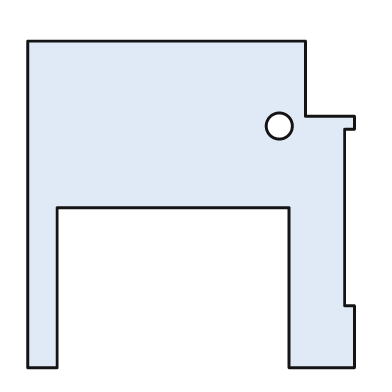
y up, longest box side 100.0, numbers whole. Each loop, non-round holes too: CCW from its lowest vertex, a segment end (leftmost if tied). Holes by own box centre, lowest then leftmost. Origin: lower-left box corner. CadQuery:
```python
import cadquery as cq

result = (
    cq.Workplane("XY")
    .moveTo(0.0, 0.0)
    .lineTo(9.0, 0.0)
    .lineTo(9.0, 49.0)
    .lineTo(80.0, 49.0)
    .lineTo(80.0, 0.0)
    .lineTo(100.0, 0.0)
    .lineTo(100.0, 19.0)
    .lineTo(97.0, 19.0)
    .lineTo(97.0, 73.0)
    .lineTo(100.0, 73.0)
    .lineTo(100.0, 77.0)
    .lineTo(85.0, 77.0)
    .lineTo(85.0, 100.0)
    .lineTo(0.0, 100.0)
    .close()
    .moveTo(77.0, 74.0)
    .circle(4.0)
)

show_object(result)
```